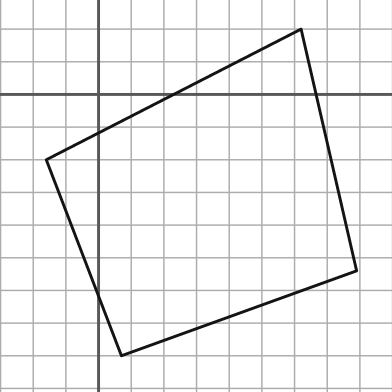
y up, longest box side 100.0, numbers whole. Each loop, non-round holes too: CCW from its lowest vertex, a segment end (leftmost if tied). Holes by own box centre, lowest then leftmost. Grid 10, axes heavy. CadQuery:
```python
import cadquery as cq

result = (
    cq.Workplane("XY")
    .moveTo(7.0, -80.0)
    .lineTo(79.0, -54.0)
    .lineTo(62.0, 20.0)
    .lineTo(-16.0, -20.0)
    .close()
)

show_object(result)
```